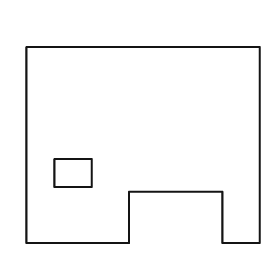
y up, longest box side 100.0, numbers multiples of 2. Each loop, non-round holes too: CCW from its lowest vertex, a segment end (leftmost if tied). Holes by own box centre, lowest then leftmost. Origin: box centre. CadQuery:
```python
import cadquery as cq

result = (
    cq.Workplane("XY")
    .moveTo(-50.0, -42.0)
    .lineTo(-6.0, -42.0)
    .lineTo(-6.0, -20.0)
    .lineTo(34.0, -20.0)
    .lineTo(34.0, -42.0)
    .lineTo(50.0, -42.0)
    .lineTo(50.0, 42.0)
    .lineTo(-50.0, 42.0)
    .close()
    .moveTo(-38.0, -18.0)
    .lineTo(-22.0, -18.0)
    .lineTo(-22.0, -6.0)
    .lineTo(-38.0, -6.0)
    .close()
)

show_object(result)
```